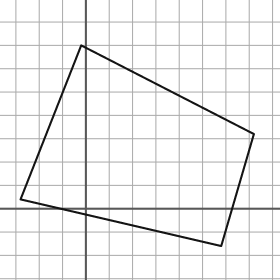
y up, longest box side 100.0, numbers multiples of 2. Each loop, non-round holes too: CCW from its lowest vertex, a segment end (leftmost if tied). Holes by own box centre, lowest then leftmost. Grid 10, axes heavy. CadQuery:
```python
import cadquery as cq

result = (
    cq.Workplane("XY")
    .moveTo(58.0, -16.0)
    .lineTo(72.0, 32.0)
    .lineTo(-2.0, 70.0)
    .lineTo(-28.0, 4.0)
    .close()
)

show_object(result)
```